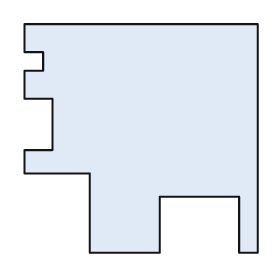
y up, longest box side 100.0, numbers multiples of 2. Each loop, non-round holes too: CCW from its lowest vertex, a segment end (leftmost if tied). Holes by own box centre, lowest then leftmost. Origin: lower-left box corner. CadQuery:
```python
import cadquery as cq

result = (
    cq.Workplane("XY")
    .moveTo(28.0, 0.0)
    .lineTo(58.0, 0.0)
    .lineTo(58.0, 24.0)
    .lineTo(92.0, 24.0)
    .lineTo(92.0, 0.0)
    .lineTo(100.0, 0.0)
    .lineTo(100.0, 98.0)
    .lineTo(0.0, 98.0)
    .lineTo(0.0, 86.0)
    .lineTo(8.0, 86.0)
    .lineTo(8.0, 78.0)
    .lineTo(0.0, 78.0)
    .lineTo(0.0, 66.0)
    .lineTo(12.0, 66.0)
    .lineTo(12.0, 44.0)
    .lineTo(0.0, 44.0)
    .lineTo(0.0, 34.0)
    .lineTo(28.0, 34.0)
    .close()
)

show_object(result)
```